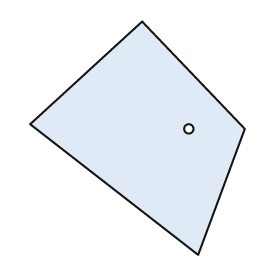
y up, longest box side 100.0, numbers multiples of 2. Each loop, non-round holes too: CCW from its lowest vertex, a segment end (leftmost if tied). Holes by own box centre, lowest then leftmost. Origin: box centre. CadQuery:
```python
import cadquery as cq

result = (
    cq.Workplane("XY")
    .moveTo(26.0, -50.0)
    .lineTo(46.0, 4.0)
    .lineTo(2.0, 50.0)
    .lineTo(-46.0, 6.0)
    .close()
    .moveTo(22.0, 4.0)
    .circle(2.0)
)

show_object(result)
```